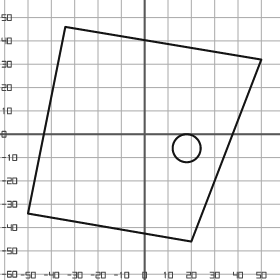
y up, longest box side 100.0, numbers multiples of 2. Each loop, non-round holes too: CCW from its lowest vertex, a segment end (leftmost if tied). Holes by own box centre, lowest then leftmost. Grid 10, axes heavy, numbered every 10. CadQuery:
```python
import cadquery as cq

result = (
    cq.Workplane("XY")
    .moveTo(20.0, -46.0)
    .lineTo(50.0, 32.0)
    .lineTo(-34.0, 46.0)
    .lineTo(-50.0, -34.0)
    .close()
    .moveTo(18.0, -6.0)
    .circle(6.0)
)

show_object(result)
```